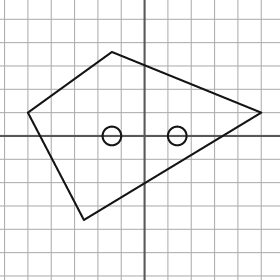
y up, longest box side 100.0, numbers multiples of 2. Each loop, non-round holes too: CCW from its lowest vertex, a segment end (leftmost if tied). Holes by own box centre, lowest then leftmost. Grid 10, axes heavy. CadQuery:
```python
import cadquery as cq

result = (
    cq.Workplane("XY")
    .moveTo(-26.0, -36.0)
    .lineTo(50.0, 10.0)
    .lineTo(-14.0, 36.0)
    .lineTo(-50.0, 10.0)
    .close()
    .moveTo(-14.0, 0.0)
    .circle(4.0)
    .moveTo(14.0, 0.0)
    .circle(4.0)
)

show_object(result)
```